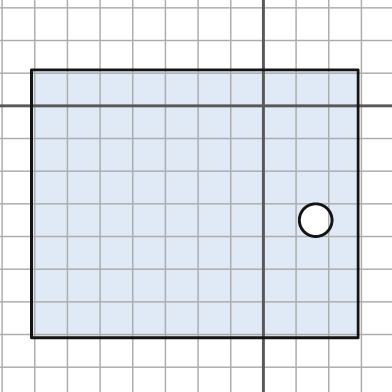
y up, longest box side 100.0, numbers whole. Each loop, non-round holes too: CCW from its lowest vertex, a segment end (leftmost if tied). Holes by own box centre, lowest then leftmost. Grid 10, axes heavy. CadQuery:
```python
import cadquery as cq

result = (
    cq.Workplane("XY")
    .moveTo(-71.0, -71.0)
    .lineTo(29.0, -71.0)
    .lineTo(29.0, 11.0)
    .lineTo(-71.0, 11.0)
    .close()
    .moveTo(16.0, -35.0)
    .circle(5.0)
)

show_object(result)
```